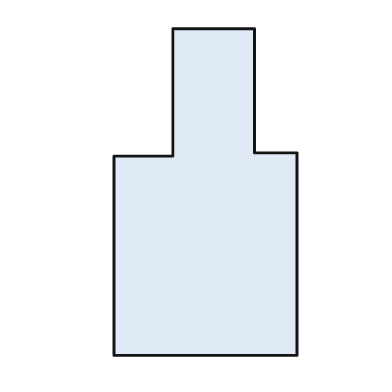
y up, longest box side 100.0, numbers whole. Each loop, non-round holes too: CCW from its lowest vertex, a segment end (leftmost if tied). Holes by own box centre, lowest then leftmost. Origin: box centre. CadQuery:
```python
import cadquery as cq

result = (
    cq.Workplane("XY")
    .moveTo(-28.0, -50.0)
    .lineTo(28.0, -50.0)
    .lineTo(28.0, 12.0)
    .lineTo(15.0, 12.0)
    .lineTo(15.0, 50.0)
    .lineTo(-10.0, 50.0)
    .lineTo(-10.0, 11.0)
    .lineTo(-28.0, 11.0)
    .close()
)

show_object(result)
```